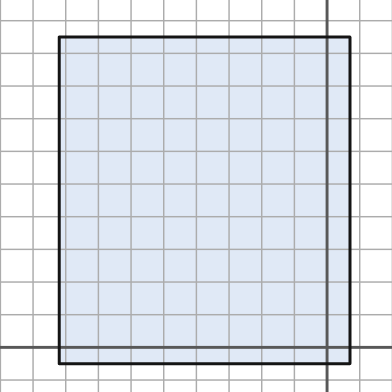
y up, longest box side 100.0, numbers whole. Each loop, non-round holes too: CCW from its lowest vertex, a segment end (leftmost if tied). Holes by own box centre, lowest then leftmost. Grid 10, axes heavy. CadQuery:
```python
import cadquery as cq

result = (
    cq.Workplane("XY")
    .moveTo(-82.0, -5.0)
    .lineTo(7.0, -5.0)
    .lineTo(7.0, 95.0)
    .lineTo(-82.0, 95.0)
    .close()
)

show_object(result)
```